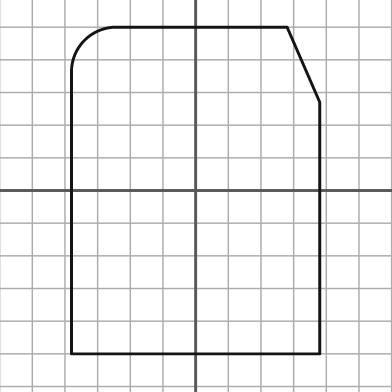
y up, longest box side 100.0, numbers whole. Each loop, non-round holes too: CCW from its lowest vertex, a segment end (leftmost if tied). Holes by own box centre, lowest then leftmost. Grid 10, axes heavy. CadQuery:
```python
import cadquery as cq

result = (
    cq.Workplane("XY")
    .moveTo(-38.0, -50.0)
    .lineTo(38.0, -50.0)
    .lineTo(38.0, 27.0)
    .lineTo(28.0, 50.0)
    .lineTo(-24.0, 50.0)
    .threePointArc((-34.0, 46.0), (-38.0, 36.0))
    .close()
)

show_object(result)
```